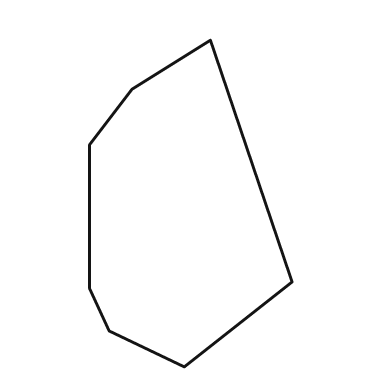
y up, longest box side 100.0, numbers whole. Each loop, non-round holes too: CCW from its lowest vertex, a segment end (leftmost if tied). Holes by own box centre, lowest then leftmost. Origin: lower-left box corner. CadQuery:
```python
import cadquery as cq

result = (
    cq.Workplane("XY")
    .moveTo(29.0, 0.0)
    .lineTo(62.0, 26.0)
    .lineTo(37.0, 100.0)
    .lineTo(13.0, 85.0)
    .lineTo(0.0, 68.0)
    .lineTo(0.0, 24.0)
    .lineTo(6.0, 11.0)
    .close()
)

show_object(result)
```